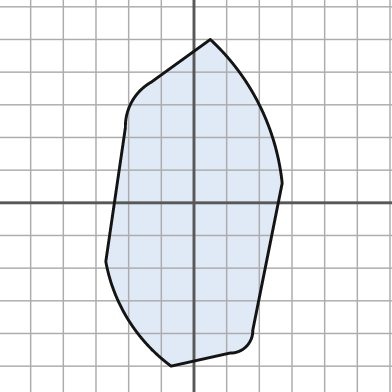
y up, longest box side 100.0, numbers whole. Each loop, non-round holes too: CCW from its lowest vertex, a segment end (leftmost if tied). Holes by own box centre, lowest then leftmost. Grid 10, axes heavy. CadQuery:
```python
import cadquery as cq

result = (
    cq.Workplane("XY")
    .moveTo(-7.0, -50.0)
    .lineTo(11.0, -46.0)
    .threePointArc((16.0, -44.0), (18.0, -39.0))
    .lineTo(27.0, 6.0)
    .threePointArc((20.0, 30.0), (5.0, 50.0))
    .lineTo(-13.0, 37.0)
    .threePointArc((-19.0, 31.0), (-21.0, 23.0))
    .lineTo(-27.0, -18.0)
    .threePointArc((-20.0, -36.0), (-7.0, -50.0))
    .close()
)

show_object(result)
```